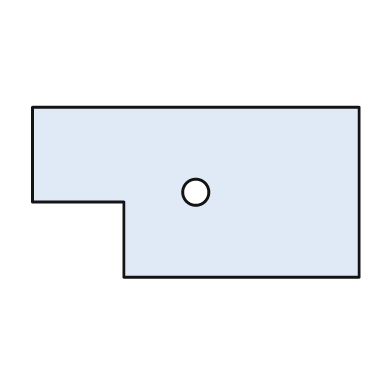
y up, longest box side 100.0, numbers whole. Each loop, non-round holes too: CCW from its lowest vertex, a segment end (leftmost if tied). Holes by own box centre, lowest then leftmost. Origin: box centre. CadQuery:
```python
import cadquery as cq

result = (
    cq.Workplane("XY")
    .moveTo(-22.0, -26.0)
    .lineTo(50.0, -26.0)
    .lineTo(50.0, 26.0)
    .lineTo(-50.0, 26.0)
    .lineTo(-50.0, -3.0)
    .lineTo(-22.0, -3.0)
    .close()
    .moveTo(0.0, 0.0)
    .circle(4.0)
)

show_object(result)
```